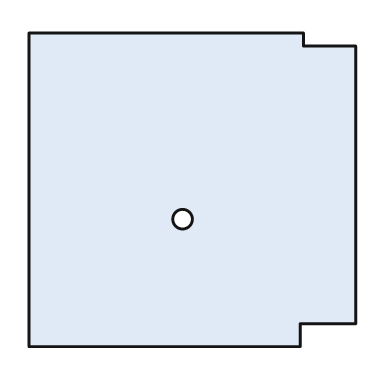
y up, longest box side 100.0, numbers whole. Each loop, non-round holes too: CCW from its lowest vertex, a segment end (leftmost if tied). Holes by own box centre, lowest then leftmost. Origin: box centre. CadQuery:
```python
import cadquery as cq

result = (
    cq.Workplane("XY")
    .moveTo(-50.0, -48.0)
    .lineTo(33.0, -48.0)
    .lineTo(33.0, -41.0)
    .lineTo(50.0, -41.0)
    .lineTo(50.0, 44.0)
    .lineTo(34.0, 44.0)
    .lineTo(34.0, 48.0)
    .lineTo(-50.0, 48.0)
    .close()
    .moveTo(-3.0, -9.0)
    .circle(3.0)
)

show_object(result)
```